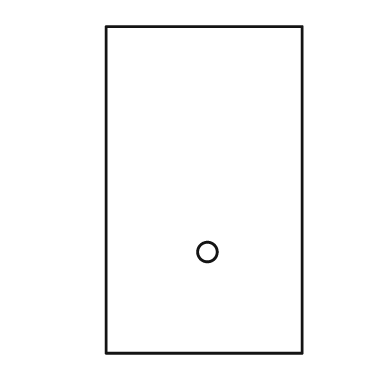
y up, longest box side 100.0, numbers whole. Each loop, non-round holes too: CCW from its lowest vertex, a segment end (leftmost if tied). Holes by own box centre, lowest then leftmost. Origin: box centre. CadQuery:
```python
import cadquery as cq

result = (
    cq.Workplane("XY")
    .moveTo(-30.0, -50.0)
    .lineTo(30.0, -50.0)
    .lineTo(30.0, 50.0)
    .lineTo(-30.0, 50.0)
    .close()
    .moveTo(1.0, -19.0)
    .circle(3.0)
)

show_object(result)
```